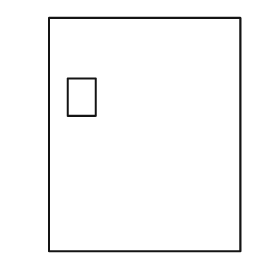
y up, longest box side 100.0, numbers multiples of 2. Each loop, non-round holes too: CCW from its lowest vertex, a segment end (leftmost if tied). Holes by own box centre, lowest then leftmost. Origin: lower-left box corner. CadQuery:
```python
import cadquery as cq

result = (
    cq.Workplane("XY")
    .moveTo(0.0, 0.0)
    .lineTo(82.0, 0.0)
    .lineTo(82.0, 100.0)
    .lineTo(0.0, 100.0)
    .close()
    .moveTo(8.0, 58.0)
    .lineTo(20.0, 58.0)
    .lineTo(20.0, 74.0)
    .lineTo(8.0, 74.0)
    .close()
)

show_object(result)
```